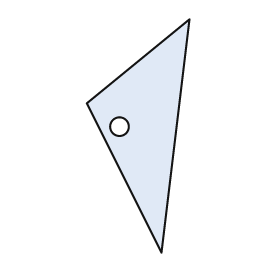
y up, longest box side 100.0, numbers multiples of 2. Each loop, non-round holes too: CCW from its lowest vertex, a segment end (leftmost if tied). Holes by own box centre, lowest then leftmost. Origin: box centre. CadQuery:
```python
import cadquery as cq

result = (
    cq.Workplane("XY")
    .moveTo(10.0, -50.0)
    .lineTo(22.0, 50.0)
    .lineTo(-22.0, 14.0)
    .close()
    .moveTo(-8.0, 4.0)
    .circle(4.0)
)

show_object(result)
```